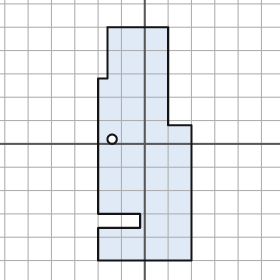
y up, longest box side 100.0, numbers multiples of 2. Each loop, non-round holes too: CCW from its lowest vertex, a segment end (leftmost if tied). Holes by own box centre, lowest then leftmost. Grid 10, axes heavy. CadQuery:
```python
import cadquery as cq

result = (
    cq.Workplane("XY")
    .moveTo(-20.0, -50.0)
    .lineTo(20.0, -50.0)
    .lineTo(20.0, 8.0)
    .lineTo(10.0, 8.0)
    .lineTo(10.0, 50.0)
    .lineTo(-16.0, 50.0)
    .lineTo(-16.0, 28.0)
    .lineTo(-20.0, 28.0)
    .lineTo(-20.0, -30.0)
    .lineTo(-2.0, -30.0)
    .lineTo(-2.0, -36.0)
    .lineTo(-20.0, -36.0)
    .close()
    .moveTo(-14.0, 2.0)
    .circle(2.0)
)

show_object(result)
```